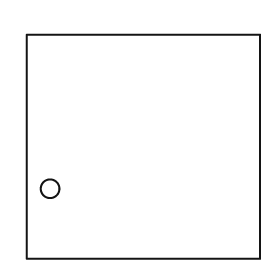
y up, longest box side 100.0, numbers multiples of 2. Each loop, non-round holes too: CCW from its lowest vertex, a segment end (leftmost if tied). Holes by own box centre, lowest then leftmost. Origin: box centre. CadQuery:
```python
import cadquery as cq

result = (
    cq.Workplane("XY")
    .moveTo(-50.0, -48.0)
    .lineTo(50.0, -48.0)
    .lineTo(50.0, 48.0)
    .lineTo(-50.0, 48.0)
    .close()
    .moveTo(-40.0, -18.0)
    .circle(4.0)
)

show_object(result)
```